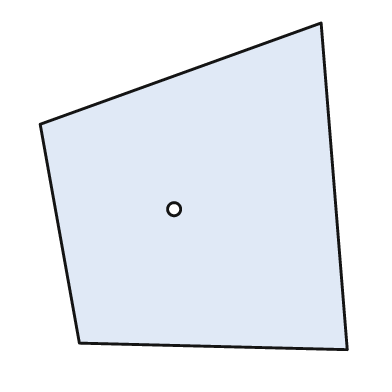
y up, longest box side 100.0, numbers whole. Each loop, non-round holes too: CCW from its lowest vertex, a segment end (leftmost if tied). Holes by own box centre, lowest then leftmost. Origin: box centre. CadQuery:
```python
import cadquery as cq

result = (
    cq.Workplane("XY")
    .moveTo(47.0, -50.0)
    .lineTo(39.0, 50.0)
    .lineTo(-47.0, 19.0)
    .lineTo(-35.0, -48.0)
    .close()
    .moveTo(-6.0, -7.0)
    .circle(2.0)
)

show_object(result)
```